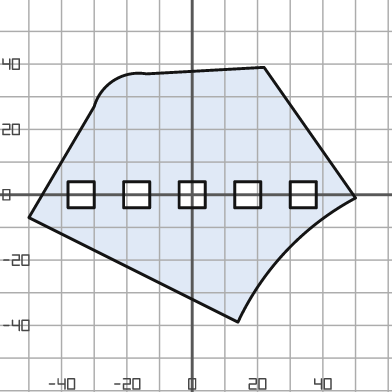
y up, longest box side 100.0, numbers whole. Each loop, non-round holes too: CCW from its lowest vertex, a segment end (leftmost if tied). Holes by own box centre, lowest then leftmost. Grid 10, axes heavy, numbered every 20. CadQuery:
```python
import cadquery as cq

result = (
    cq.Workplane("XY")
    .moveTo(14.0, -39.0)
    .threePointArc((29.0, -17.0), (50.0, -1.0))
    .lineTo(22.0, 39.0)
    .lineTo(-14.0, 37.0)
    .threePointArc((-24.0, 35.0), (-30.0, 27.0))
    .lineTo(-50.0, -7.0)
    .close()
    .moveTo(-38.0, -4.0)
    .lineTo(-30.0, -4.0)
    .lineTo(-30.0, 4.0)
    .lineTo(-38.0, 4.0)
    .close()
    .moveTo(-21.0, -4.0)
    .lineTo(-13.0, -4.0)
    .lineTo(-13.0, 4.0)
    .lineTo(-21.0, 4.0)
    .close()
    .moveTo(-4.0, -4.0)
    .lineTo(4.0, -4.0)
    .lineTo(4.0, 4.0)
    .lineTo(-4.0, 4.0)
    .close()
    .moveTo(13.0, -4.0)
    .lineTo(21.0, -4.0)
    .lineTo(21.0, 4.0)
    .lineTo(13.0, 4.0)
    .close()
    .moveTo(30.0, -4.0)
    .lineTo(38.0, -4.0)
    .lineTo(38.0, 4.0)
    .lineTo(30.0, 4.0)
    .close()
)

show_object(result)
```